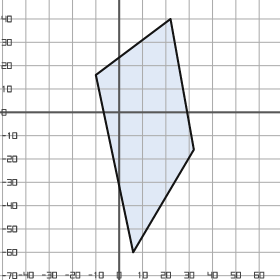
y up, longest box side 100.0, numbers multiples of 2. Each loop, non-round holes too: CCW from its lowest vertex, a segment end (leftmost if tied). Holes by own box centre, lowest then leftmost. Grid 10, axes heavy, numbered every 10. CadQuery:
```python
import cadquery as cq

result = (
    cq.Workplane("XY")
    .moveTo(6.0, -60.0)
    .lineTo(32.0, -16.0)
    .lineTo(22.0, 40.0)
    .lineTo(-10.0, 16.0)
    .close()
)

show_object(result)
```